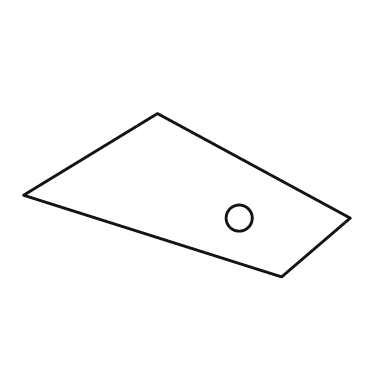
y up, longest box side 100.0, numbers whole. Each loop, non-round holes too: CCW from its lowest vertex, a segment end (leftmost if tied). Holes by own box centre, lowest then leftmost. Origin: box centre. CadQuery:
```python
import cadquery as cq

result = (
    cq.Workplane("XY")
    .moveTo(29.0, -25.0)
    .lineTo(50.0, -7.0)
    .lineTo(-9.0, 25.0)
    .lineTo(-50.0, 0.0)
    .close()
    .moveTo(16.0, -7.0)
    .circle(4.0)
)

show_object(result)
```